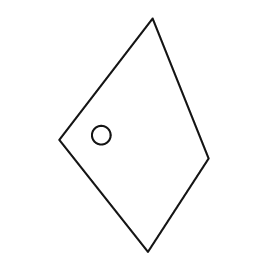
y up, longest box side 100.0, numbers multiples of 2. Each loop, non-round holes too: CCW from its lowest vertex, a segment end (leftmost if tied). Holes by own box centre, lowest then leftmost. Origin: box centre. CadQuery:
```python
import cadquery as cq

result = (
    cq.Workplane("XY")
    .moveTo(6.0, -50.0)
    .lineTo(32.0, -10.0)
    .lineTo(8.0, 50.0)
    .lineTo(-32.0, -2.0)
    .close()
    .moveTo(-14.0, 0.0)
    .circle(4.0)
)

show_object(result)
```